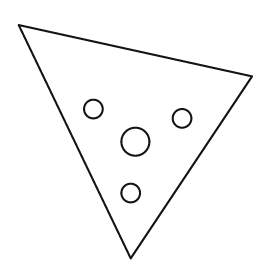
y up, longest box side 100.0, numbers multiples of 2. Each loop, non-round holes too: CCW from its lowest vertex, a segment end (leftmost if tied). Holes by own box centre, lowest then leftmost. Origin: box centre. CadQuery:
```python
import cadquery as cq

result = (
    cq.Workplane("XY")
    .moveTo(-2.0, -50.0)
    .lineTo(50.0, 28.0)
    .lineTo(-50.0, 50.0)
    .close()
    .moveTo(-2.0, -22.0)
    .circle(4.0)
    .moveTo(0.0, 0.0)
    .circle(6.0)
    .moveTo(20.0, 10.0)
    .circle(4.0)
    .moveTo(-18.0, 14.0)
    .circle(4.0)
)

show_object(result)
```